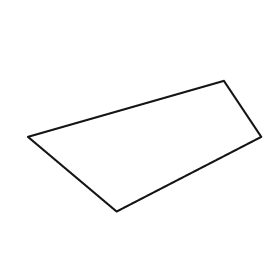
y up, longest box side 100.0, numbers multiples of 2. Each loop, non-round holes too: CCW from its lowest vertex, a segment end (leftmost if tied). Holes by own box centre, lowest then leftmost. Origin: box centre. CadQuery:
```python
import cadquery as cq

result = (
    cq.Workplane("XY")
    .moveTo(-12.0, -28.0)
    .lineTo(50.0, 4.0)
    .lineTo(34.0, 28.0)
    .lineTo(-50.0, 4.0)
    .close()
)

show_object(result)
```